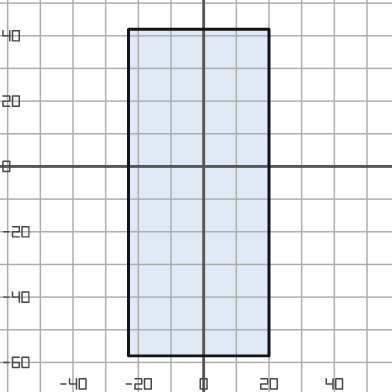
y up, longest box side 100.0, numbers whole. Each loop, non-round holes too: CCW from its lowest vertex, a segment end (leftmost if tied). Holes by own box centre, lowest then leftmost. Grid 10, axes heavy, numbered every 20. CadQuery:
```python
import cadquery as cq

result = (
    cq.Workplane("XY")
    .moveTo(-23.0, -58.0)
    .lineTo(20.0, -58.0)
    .lineTo(20.0, 42.0)
    .lineTo(-23.0, 42.0)
    .close()
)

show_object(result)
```